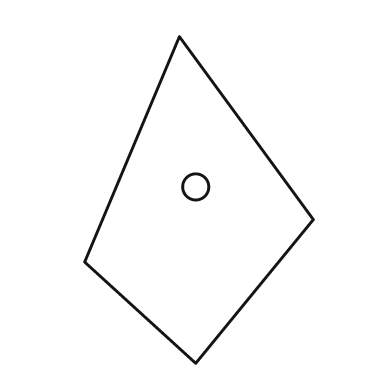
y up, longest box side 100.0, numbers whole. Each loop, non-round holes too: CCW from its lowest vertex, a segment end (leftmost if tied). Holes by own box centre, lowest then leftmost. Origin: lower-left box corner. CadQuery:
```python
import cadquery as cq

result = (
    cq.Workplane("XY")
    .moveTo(34.0, 0.0)
    .lineTo(70.0, 44.0)
    .lineTo(29.0, 100.0)
    .lineTo(0.0, 31.0)
    .close()
    .moveTo(34.0, 54.0)
    .circle(4.0)
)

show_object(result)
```